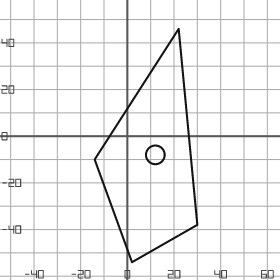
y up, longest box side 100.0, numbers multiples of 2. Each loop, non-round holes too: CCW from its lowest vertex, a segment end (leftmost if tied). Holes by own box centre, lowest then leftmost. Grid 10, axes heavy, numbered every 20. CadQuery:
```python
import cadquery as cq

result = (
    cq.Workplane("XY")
    .moveTo(2.0, -54.0)
    .lineTo(30.0, -38.0)
    .lineTo(22.0, 46.0)
    .lineTo(-14.0, -10.0)
    .close()
    .moveTo(12.0, -8.0)
    .circle(4.0)
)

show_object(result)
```